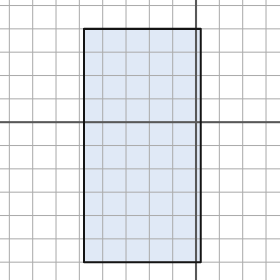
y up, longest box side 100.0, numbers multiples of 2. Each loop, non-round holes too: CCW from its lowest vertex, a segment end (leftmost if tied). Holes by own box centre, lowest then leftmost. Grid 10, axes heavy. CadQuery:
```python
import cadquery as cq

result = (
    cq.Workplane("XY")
    .moveTo(-48.0, -60.0)
    .lineTo(2.0, -60.0)
    .lineTo(2.0, 40.0)
    .lineTo(-48.0, 40.0)
    .close()
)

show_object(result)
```